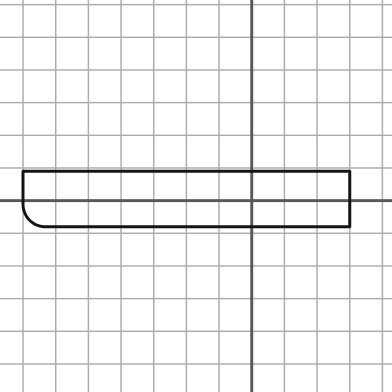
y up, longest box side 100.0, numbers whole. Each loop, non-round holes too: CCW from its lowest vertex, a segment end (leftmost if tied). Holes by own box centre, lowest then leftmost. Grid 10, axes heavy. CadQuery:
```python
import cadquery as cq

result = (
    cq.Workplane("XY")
    .moveTo(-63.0, -8.0)
    .lineTo(30.0, -8.0)
    .lineTo(30.0, 9.0)
    .lineTo(-70.0, 9.0)
    .lineTo(-70.0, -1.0)
    .threePointArc((-68.0, -6.0), (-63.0, -8.0))
    .close()
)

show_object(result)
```